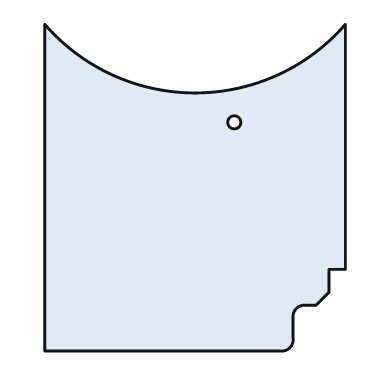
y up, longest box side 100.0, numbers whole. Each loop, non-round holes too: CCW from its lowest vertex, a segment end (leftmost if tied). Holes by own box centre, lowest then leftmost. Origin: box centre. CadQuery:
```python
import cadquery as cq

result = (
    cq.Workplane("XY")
    .moveTo(-46.0, -50.0)
    .lineTo(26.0, -50.0)
    .threePointArc((29.0, -49.0), (30.0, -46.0))
    .lineTo(30.0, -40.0)
    .threePointArc((31.0, -37.0), (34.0, -36.0))
    .lineTo(37.0, -36.0)
    .lineTo(41.0, -32.0)
    .lineTo(41.0, -25.0)
    .lineTo(46.0, -25.0)
    .lineTo(46.0, 50.0)
    .threePointArc((0.0, 29.0), (-46.0, 50.0))
    .close()
    .moveTo(12.0, 20.0)
    .circle(2.0)
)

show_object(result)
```